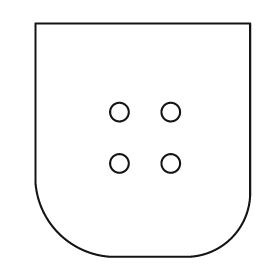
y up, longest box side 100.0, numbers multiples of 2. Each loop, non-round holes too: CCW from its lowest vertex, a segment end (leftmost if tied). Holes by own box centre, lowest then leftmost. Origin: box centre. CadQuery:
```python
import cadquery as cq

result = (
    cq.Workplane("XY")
    .moveTo(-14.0, -50.0)
    .lineTo(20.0, -50.0)
    .threePointArc((38.0, -42.0), (46.0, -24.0))
    .lineTo(46.0, 50.0)
    .lineTo(-46.0, 50.0)
    .lineTo(-46.0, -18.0)
    .threePointArc((-36.0, -40.0), (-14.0, -50.0))
    .close()
    .moveTo(-10.0, -10.0)
    .circle(4.0)
    .moveTo(12.0, -10.0)
    .circle(4.0)
    .moveTo(-10.0, 12.0)
    .circle(4.0)
    .moveTo(12.0, 12.0)
    .circle(4.0)
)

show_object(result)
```